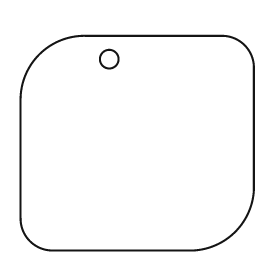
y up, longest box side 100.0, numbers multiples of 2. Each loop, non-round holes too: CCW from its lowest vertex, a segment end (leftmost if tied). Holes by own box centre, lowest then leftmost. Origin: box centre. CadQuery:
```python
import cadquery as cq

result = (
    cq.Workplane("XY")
    .moveTo(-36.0, -46.0)
    .lineTo(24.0, -46.0)
    .threePointArc((42.0, -38.0), (50.0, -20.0))
    .lineTo(50.0, 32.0)
    .threePointArc((46.0, 42.0), (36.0, 46.0))
    .lineTo(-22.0, 46.0)
    .threePointArc((-42.0, 38.0), (-50.0, 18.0))
    .lineTo(-50.0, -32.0)
    .threePointArc((-46.0, -42.0), (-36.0, -46.0))
    .close()
    .moveTo(-12.0, 36.0)
    .circle(4.0)
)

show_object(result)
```